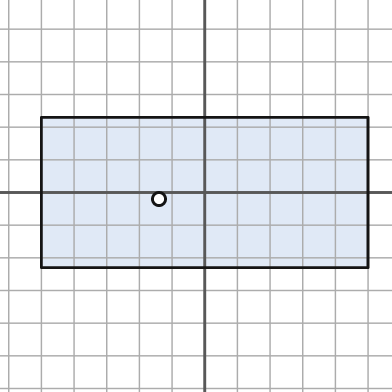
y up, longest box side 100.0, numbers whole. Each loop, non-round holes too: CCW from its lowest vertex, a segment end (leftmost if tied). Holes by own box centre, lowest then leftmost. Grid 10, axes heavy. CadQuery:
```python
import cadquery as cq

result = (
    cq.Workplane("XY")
    .moveTo(-50.0, -23.0)
    .lineTo(50.0, -23.0)
    .lineTo(50.0, 23.0)
    .lineTo(-50.0, 23.0)
    .close()
    .moveTo(-14.0, -2.0)
    .circle(2.0)
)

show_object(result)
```